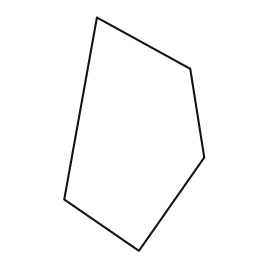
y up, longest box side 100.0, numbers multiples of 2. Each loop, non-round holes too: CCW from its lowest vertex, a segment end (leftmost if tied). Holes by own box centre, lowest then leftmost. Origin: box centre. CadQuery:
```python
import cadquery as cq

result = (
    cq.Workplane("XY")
    .moveTo(2.0, -50.0)
    .lineTo(30.0, -10.0)
    .lineTo(24.0, 28.0)
    .lineTo(-16.0, 50.0)
    .lineTo(-30.0, -28.0)
    .close()
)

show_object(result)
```